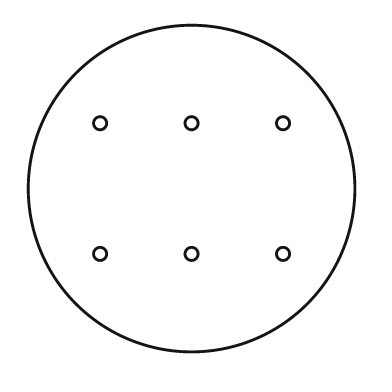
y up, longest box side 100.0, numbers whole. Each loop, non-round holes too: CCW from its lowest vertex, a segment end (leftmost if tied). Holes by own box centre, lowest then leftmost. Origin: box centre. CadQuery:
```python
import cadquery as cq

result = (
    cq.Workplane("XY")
    .moveTo(0.0, 0.0)
    .circle(50.0)
    .moveTo(-28.0, -20.0)
    .circle(2.0)
    .moveTo(0.0, -20.0)
    .circle(2.0)
    .moveTo(28.0, -20.0)
    .circle(2.0)
    .moveTo(-28.0, 20.0)
    .circle(2.0)
    .moveTo(0.0, 20.0)
    .circle(2.0)
    .moveTo(28.0, 20.0)
    .circle(2.0)
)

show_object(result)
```